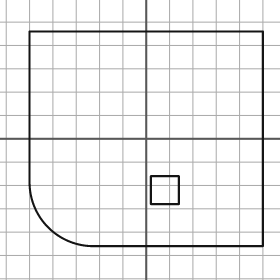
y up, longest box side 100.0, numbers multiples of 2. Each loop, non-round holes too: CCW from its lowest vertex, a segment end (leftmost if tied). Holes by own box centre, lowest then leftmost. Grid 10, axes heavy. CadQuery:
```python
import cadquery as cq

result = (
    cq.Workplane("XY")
    .moveTo(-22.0, -46.0)
    .lineTo(50.0, -46.0)
    .lineTo(50.0, 46.0)
    .lineTo(-50.0, 46.0)
    .lineTo(-50.0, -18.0)
    .threePointArc((-42.0, -38.0), (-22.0, -46.0))
    .close()
    .moveTo(2.0, -28.0)
    .lineTo(14.0, -28.0)
    .lineTo(14.0, -16.0)
    .lineTo(2.0, -16.0)
    .close()
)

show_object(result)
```